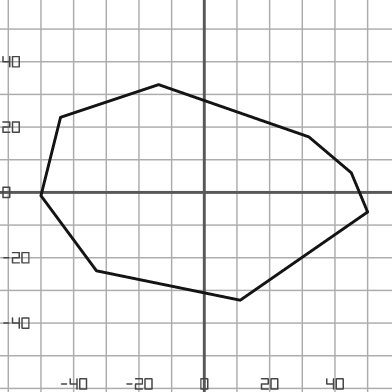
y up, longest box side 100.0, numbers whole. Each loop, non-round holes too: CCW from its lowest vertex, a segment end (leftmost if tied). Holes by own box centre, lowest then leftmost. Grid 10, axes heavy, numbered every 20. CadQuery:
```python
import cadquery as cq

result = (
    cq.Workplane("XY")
    .moveTo(11.0, -33.0)
    .lineTo(50.0, -6.0)
    .lineTo(45.0, 6.0)
    .lineTo(32.0, 17.0)
    .lineTo(-14.0, 33.0)
    .lineTo(-44.0, 23.0)
    .lineTo(-50.0, -1.0)
    .lineTo(-33.0, -24.0)
    .close()
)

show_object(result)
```